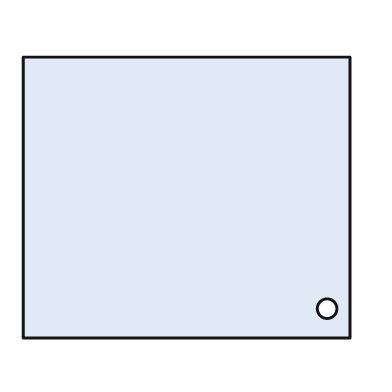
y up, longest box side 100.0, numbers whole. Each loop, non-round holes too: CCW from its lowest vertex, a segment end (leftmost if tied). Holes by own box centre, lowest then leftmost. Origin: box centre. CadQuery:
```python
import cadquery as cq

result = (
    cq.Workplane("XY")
    .moveTo(-50.0, -43.0)
    .lineTo(50.0, -43.0)
    .lineTo(50.0, 43.0)
    .lineTo(-50.0, 43.0)
    .close()
    .moveTo(43.0, -34.0)
    .circle(3.0)
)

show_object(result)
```